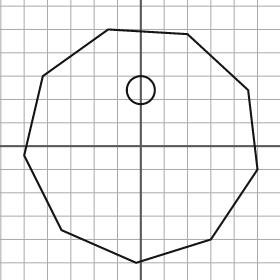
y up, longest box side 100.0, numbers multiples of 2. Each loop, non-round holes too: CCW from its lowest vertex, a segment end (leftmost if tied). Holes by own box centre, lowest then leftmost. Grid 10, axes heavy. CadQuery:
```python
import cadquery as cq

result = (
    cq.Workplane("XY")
    .moveTo(-2.0, -50.0)
    .lineTo(30.0, -40.0)
    .lineTo(50.0, -10.0)
    .lineTo(46.0, 24.0)
    .lineTo(20.0, 48.0)
    .lineTo(-14.0, 50.0)
    .lineTo(-42.0, 30.0)
    .lineTo(-50.0, -4.0)
    .lineTo(-34.0, -36.0)
    .close()
    .moveTo(0.0, 24.0)
    .circle(6.0)
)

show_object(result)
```